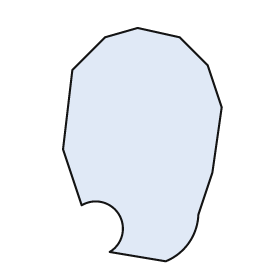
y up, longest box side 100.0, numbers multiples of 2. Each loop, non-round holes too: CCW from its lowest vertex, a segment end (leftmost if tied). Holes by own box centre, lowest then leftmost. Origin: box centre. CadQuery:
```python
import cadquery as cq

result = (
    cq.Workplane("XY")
    .moveTo(10.0, -50.0)
    .threePointArc((20.0, -42.0), (24.0, -30.0))
    .lineTo(30.0, -12.0)
    .lineTo(34.0, 16.0)
    .lineTo(28.0, 34.0)
    .lineTo(16.0, 46.0)
    .lineTo(-2.0, 50.0)
    .lineTo(-16.0, 46.0)
    .lineTo(-30.0, 32.0)
    .lineTo(-34.0, -2.0)
    .lineTo(-26.0, -26.0)
    .threePointArc((-10.0, -30.0), (-14.0, -46.0))
    .close()
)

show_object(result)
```